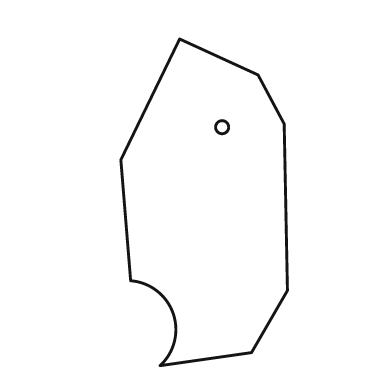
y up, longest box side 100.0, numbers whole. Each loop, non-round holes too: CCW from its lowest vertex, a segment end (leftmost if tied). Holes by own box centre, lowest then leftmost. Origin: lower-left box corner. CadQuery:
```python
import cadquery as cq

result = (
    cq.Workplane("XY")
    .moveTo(12.0, 0.0)
    .lineTo(40.0, 4.0)
    .lineTo(51.0, 23.0)
    .lineTo(50.0, 74.0)
    .lineTo(42.0, 89.0)
    .lineTo(18.0, 100.0)
    .lineTo(0.0, 63.0)
    .lineTo(3.0, 26.0)
    .threePointArc((16.0, 16.0), (12.0, 0.0))
    .close()
    .moveTo(31.0, 73.0)
    .circle(2.0)
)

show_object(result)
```